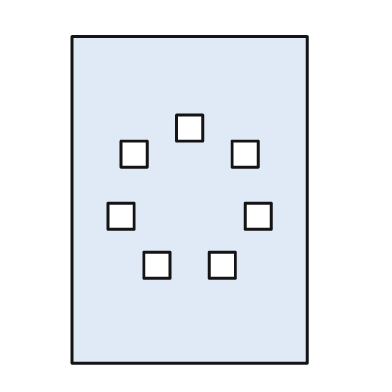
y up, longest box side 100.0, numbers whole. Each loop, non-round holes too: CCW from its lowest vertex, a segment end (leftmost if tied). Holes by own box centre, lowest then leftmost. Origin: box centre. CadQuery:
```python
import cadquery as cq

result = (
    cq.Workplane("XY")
    .moveTo(-36.0, -50.0)
    .lineTo(36.0, -50.0)
    .lineTo(36.0, 50.0)
    .lineTo(-36.0, 50.0)
    .close()
    .moveTo(-14.0, -24.0)
    .lineTo(-6.0, -24.0)
    .lineTo(-6.0, -16.0)
    .lineTo(-14.0, -16.0)
    .close()
    .moveTo(6.0, -24.0)
    .lineTo(14.0, -24.0)
    .lineTo(14.0, -16.0)
    .lineTo(6.0, -16.0)
    .close()
    .moveTo(-25.0, -9.0)
    .lineTo(-17.0, -9.0)
    .lineTo(-17.0, -1.0)
    .lineTo(-25.0, -1.0)
    .close()
    .moveTo(17.0, -9.0)
    .lineTo(25.0, -9.0)
    .lineTo(25.0, -1.0)
    .lineTo(17.0, -1.0)
    .close()
    .moveTo(-21.0, 10.0)
    .lineTo(-13.0, 10.0)
    .lineTo(-13.0, 18.0)
    .lineTo(-21.0, 18.0)
    .close()
    .moveTo(13.0, 10.0)
    .lineTo(21.0, 10.0)
    .lineTo(21.0, 18.0)
    .lineTo(13.0, 18.0)
    .close()
    .moveTo(-4.0, 18.0)
    .lineTo(4.0, 18.0)
    .lineTo(4.0, 26.0)
    .lineTo(-4.0, 26.0)
    .close()
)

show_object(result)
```